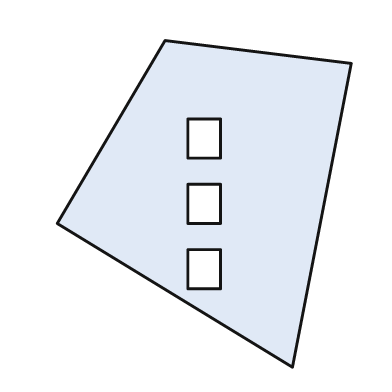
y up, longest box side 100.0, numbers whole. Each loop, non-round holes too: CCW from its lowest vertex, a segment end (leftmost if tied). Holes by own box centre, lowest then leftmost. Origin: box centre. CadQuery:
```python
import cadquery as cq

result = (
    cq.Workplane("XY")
    .moveTo(27.0, -50.0)
    .lineTo(45.0, 43.0)
    .lineTo(-12.0, 50.0)
    .lineTo(-45.0, -6.0)
    .close()
    .moveTo(-5.0, -26.0)
    .lineTo(5.0, -26.0)
    .lineTo(5.0, -14.0)
    .lineTo(-5.0, -14.0)
    .close()
    .moveTo(-5.0, -6.0)
    .lineTo(5.0, -6.0)
    .lineTo(5.0, 6.0)
    .lineTo(-5.0, 6.0)
    .close()
    .moveTo(-5.0, 14.0)
    .lineTo(5.0, 14.0)
    .lineTo(5.0, 26.0)
    .lineTo(-5.0, 26.0)
    .close()
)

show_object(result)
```